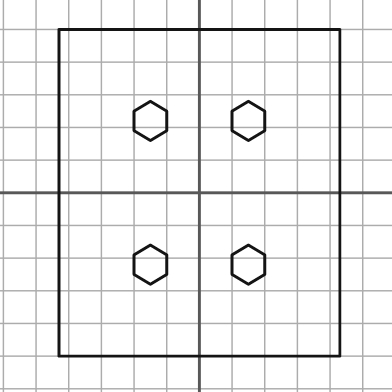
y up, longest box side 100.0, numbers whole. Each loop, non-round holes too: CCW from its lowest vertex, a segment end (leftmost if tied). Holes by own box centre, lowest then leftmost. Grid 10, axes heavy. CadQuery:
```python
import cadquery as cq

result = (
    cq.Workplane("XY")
    .moveTo(-43.0, -50.0)
    .lineTo(43.0, -50.0)
    .lineTo(43.0, 50.0)
    .lineTo(-43.0, 50.0)
    .close()
    .moveTo(-15.0, -28.0)
    .lineTo(-10.0, -25.0)
    .lineTo(-10.0, -19.0)
    .lineTo(-15.0, -16.0)
    .lineTo(-20.0, -19.0)
    .lineTo(-20.0, -25.0)
    .close()
    .moveTo(15.0, -28.0)
    .lineTo(20.0, -25.0)
    .lineTo(20.0, -19.0)
    .lineTo(15.0, -16.0)
    .lineTo(10.0, -19.0)
    .lineTo(10.0, -25.0)
    .close()
    .moveTo(-15.0, 16.0)
    .lineTo(-10.0, 19.0)
    .lineTo(-10.0, 25.0)
    .lineTo(-15.0, 28.0)
    .lineTo(-20.0, 25.0)
    .lineTo(-20.0, 19.0)
    .close()
    .moveTo(15.0, 16.0)
    .lineTo(20.0, 19.0)
    .lineTo(20.0, 25.0)
    .lineTo(15.0, 28.0)
    .lineTo(10.0, 25.0)
    .lineTo(10.0, 19.0)
    .close()
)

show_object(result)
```